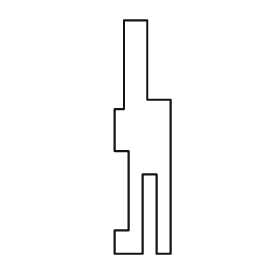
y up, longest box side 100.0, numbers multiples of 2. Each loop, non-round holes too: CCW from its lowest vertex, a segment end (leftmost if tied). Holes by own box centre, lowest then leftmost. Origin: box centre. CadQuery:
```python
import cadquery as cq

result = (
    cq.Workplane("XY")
    .moveTo(-12.0, -50.0)
    .lineTo(0.0, -50.0)
    .lineTo(0.0, -16.0)
    .lineTo(6.0, -16.0)
    .lineTo(6.0, -50.0)
    .lineTo(12.0, -50.0)
    .lineTo(12.0, 16.0)
    .lineTo(2.0, 16.0)
    .lineTo(2.0, 50.0)
    .lineTo(-8.0, 50.0)
    .lineTo(-8.0, 12.0)
    .lineTo(-12.0, 12.0)
    .lineTo(-12.0, -6.0)
    .lineTo(-6.0, -6.0)
    .lineTo(-6.0, -40.0)
    .lineTo(-12.0, -40.0)
    .close()
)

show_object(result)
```